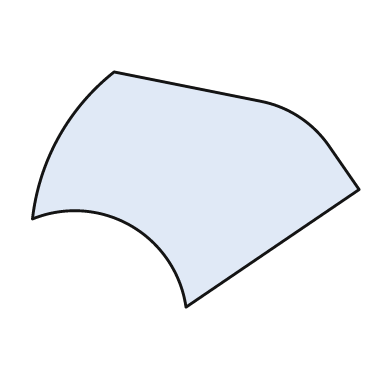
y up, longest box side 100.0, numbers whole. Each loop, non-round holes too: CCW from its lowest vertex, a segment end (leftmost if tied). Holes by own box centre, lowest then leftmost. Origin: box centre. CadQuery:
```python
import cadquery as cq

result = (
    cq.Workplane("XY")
    .moveTo(-3.0, -36.0)
    .lineTo(50.0, 0.0)
    .lineTo(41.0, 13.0)
    .threePointArc((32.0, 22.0), (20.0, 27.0))
    .lineTo(-25.0, 36.0)
    .threePointArc((-42.0, 16.0), (-50.0, -9.0))
    .threePointArc((-20.0, -11.0), (-3.0, -36.0))
    .close()
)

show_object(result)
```